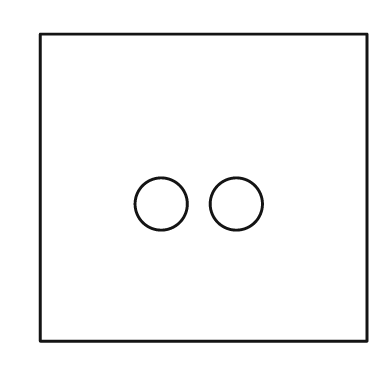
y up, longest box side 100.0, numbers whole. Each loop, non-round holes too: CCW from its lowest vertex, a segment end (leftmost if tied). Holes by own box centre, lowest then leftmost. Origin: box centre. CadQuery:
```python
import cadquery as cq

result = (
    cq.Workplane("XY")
    .moveTo(-50.0, -47.0)
    .lineTo(50.0, -47.0)
    .lineTo(50.0, 47.0)
    .lineTo(-50.0, 47.0)
    .close()
    .moveTo(-13.0, -5.0)
    .circle(8.0)
    .moveTo(10.0, -5.0)
    .circle(8.0)
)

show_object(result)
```